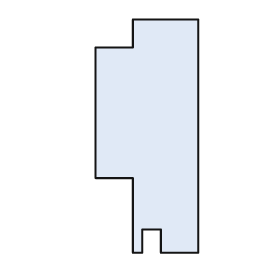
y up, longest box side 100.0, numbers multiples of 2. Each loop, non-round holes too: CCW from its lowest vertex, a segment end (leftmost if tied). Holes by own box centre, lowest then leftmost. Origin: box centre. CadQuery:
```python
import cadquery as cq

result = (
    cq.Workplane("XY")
    .moveTo(-6.0, -50.0)
    .lineTo(-2.0, -50.0)
    .lineTo(-2.0, -40.0)
    .lineTo(6.0, -40.0)
    .lineTo(6.0, -50.0)
    .lineTo(22.0, -50.0)
    .lineTo(22.0, 50.0)
    .lineTo(-6.0, 50.0)
    .lineTo(-6.0, 38.0)
    .lineTo(-22.0, 38.0)
    .lineTo(-22.0, -18.0)
    .lineTo(-6.0, -18.0)
    .close()
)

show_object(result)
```